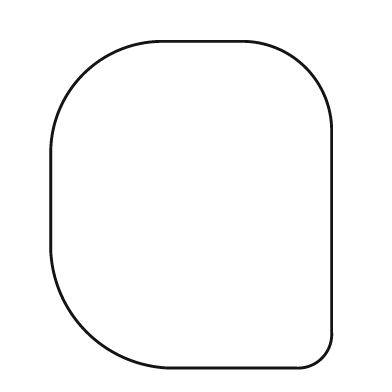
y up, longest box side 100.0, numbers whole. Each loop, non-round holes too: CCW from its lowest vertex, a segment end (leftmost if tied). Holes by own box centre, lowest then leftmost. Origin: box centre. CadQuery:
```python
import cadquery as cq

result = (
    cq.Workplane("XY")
    .moveTo(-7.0, -50.0)
    .lineTo(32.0, -50.0)
    .threePointArc((40.0, -47.0), (43.0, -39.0))
    .lineTo(43.0, 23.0)
    .threePointArc((35.0, 42.0), (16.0, 50.0))
    .lineTo(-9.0, 50.0)
    .threePointArc((-33.0, 40.0), (-43.0, 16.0))
    .lineTo(-43.0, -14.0)
    .threePointArc((-32.0, -39.0), (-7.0, -50.0))
    .close()
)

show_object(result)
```